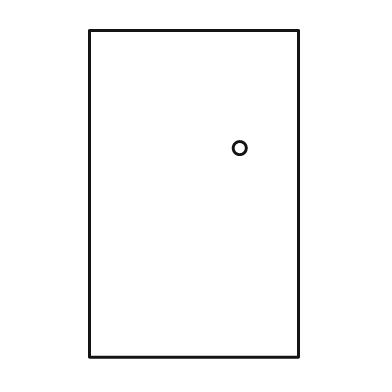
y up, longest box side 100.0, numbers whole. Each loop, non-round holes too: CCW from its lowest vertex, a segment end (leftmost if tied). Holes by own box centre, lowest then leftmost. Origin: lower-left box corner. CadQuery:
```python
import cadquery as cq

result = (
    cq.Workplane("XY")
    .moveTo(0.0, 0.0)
    .lineTo(64.0, 0.0)
    .lineTo(64.0, 100.0)
    .lineTo(0.0, 100.0)
    .close()
    .moveTo(46.0, 64.0)
    .circle(2.0)
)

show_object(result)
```